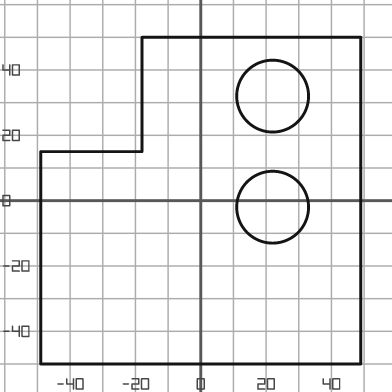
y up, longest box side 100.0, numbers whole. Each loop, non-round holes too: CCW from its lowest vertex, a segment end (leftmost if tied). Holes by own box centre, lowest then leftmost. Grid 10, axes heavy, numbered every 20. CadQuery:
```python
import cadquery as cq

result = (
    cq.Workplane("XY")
    .moveTo(-49.0, -50.0)
    .lineTo(49.0, -50.0)
    .lineTo(49.0, 50.0)
    .lineTo(-18.0, 50.0)
    .lineTo(-18.0, 15.0)
    .lineTo(-49.0, 15.0)
    .close()
    .moveTo(22.0, -2.0)
    .circle(11.0)
    .moveTo(22.0, 32.0)
    .circle(11.0)
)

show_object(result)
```